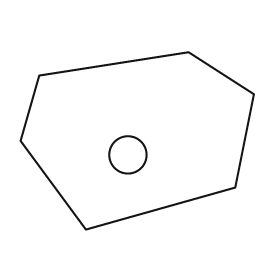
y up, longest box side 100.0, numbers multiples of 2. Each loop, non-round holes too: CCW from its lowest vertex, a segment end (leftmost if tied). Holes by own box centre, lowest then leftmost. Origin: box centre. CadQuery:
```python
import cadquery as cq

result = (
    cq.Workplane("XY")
    .moveTo(-22.0, -38.0)
    .lineTo(42.0, -20.0)
    .lineTo(50.0, 20.0)
    .lineTo(22.0, 38.0)
    .lineTo(-42.0, 28.0)
    .lineTo(-50.0, 0.0)
    .close()
    .moveTo(-4.0, -6.0)
    .circle(8.0)
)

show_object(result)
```